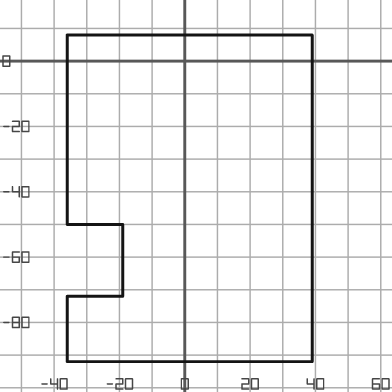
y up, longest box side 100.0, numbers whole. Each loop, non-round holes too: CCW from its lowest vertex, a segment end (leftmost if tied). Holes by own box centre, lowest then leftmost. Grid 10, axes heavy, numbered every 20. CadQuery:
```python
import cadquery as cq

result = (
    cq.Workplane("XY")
    .moveTo(-36.0, -92.0)
    .lineTo(39.0, -92.0)
    .lineTo(39.0, 8.0)
    .lineTo(-36.0, 8.0)
    .lineTo(-36.0, -50.0)
    .lineTo(-19.0, -50.0)
    .lineTo(-19.0, -72.0)
    .lineTo(-36.0, -72.0)
    .close()
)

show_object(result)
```